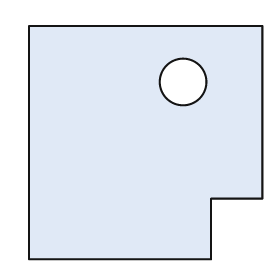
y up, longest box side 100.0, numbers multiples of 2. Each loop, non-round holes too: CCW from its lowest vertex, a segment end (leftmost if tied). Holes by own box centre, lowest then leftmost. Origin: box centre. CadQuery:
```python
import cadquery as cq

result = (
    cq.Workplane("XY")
    .moveTo(-50.0, -50.0)
    .lineTo(28.0, -50.0)
    .lineTo(28.0, -24.0)
    .lineTo(50.0, -24.0)
    .lineTo(50.0, 50.0)
    .lineTo(-50.0, 50.0)
    .close()
    .moveTo(16.0, 26.0)
    .circle(10.0)
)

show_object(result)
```